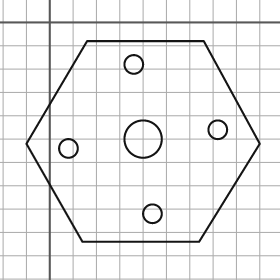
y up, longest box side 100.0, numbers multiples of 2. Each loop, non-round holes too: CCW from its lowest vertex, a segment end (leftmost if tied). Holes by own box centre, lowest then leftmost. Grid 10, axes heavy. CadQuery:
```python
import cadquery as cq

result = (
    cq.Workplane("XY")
    .moveTo(14.0, -94.0)
    .lineTo(64.0, -94.0)
    .lineTo(90.0, -52.0)
    .lineTo(66.0, -8.0)
    .lineTo(16.0, -8.0)
    .lineTo(-10.0, -52.0)
    .close()
    .moveTo(44.0, -82.0)
    .circle(4.0)
    .moveTo(8.0, -54.0)
    .circle(4.0)
    .moveTo(40.0, -50.0)
    .circle(8.0)
    .moveTo(72.0, -46.0)
    .circle(4.0)
    .moveTo(36.0, -18.0)
    .circle(4.0)
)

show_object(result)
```